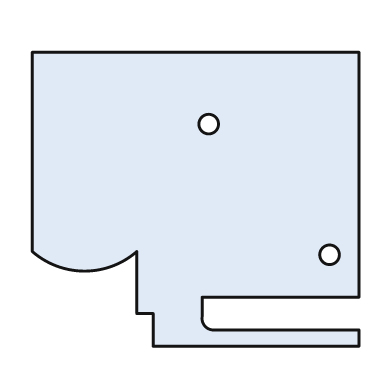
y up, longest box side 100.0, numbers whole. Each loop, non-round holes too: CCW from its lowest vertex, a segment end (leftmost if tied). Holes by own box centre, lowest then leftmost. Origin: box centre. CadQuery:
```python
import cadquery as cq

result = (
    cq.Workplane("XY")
    .moveTo(-13.0, -45.0)
    .lineTo(50.0, -45.0)
    .lineTo(50.0, -40.0)
    .lineTo(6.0, -40.0)
    .threePointArc((3.0, -39.0), (2.0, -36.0))
    .lineTo(2.0, -30.0)
    .lineTo(50.0, -30.0)
    .lineTo(50.0, 45.0)
    .lineTo(-50.0, 45.0)
    .lineTo(-50.0, -16.0)
    .threePointArc((-34.0, -22.0), (-18.0, -16.0))
    .lineTo(-18.0, -35.0)
    .lineTo(-13.0, -35.0)
    .close()
    .moveTo(41.0, -17.0)
    .circle(3.0)
    .moveTo(4.0, 23.0)
    .circle(3.0)
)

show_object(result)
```